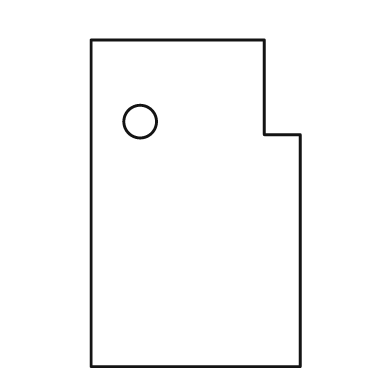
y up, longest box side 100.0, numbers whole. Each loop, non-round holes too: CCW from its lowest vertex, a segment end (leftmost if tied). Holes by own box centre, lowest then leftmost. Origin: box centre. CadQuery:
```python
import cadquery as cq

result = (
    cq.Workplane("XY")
    .moveTo(-32.0, -50.0)
    .lineTo(32.0, -50.0)
    .lineTo(32.0, 21.0)
    .lineTo(21.0, 21.0)
    .lineTo(21.0, 50.0)
    .lineTo(-32.0, 50.0)
    .close()
    .moveTo(-17.0, 25.0)
    .circle(5.0)
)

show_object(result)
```